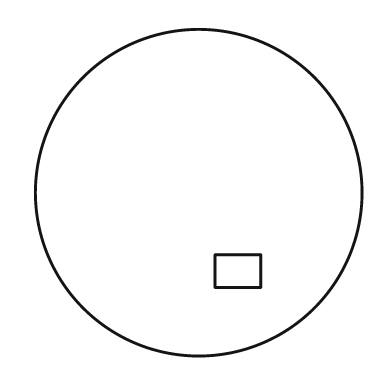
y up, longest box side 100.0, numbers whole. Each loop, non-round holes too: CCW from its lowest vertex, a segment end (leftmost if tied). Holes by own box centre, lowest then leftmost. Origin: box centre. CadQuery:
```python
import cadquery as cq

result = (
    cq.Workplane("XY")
    .moveTo(0.0, 0.0)
    .circle(50.0)
    .moveTo(5.0, -29.0)
    .lineTo(19.0, -29.0)
    .lineTo(19.0, -19.0)
    .lineTo(5.0, -19.0)
    .close()
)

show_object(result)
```